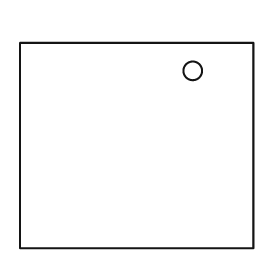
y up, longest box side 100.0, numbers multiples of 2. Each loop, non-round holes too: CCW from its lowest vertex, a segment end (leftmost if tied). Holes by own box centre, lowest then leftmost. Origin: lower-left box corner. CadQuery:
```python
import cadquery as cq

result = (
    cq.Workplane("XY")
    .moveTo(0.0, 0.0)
    .lineTo(100.0, 0.0)
    .lineTo(100.0, 88.0)
    .lineTo(0.0, 88.0)
    .close()
    .moveTo(74.0, 76.0)
    .circle(4.0)
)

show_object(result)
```